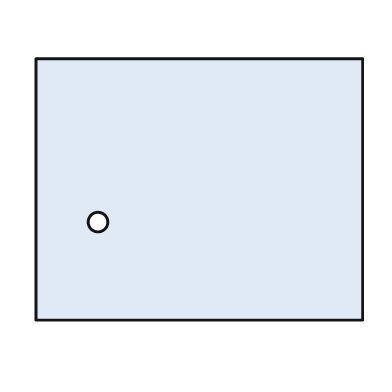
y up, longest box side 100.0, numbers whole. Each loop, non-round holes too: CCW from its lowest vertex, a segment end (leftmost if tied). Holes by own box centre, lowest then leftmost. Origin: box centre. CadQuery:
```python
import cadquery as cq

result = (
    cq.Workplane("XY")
    .moveTo(-50.0, -40.0)
    .lineTo(50.0, -40.0)
    .lineTo(50.0, 40.0)
    .lineTo(-50.0, 40.0)
    .close()
    .moveTo(-31.0, -10.0)
    .circle(3.0)
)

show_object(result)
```